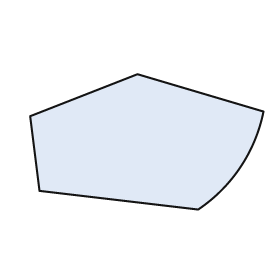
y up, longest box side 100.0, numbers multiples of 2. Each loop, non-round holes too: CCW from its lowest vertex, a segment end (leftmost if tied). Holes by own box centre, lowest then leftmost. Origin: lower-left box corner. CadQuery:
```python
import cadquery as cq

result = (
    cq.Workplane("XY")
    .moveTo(72.0, 0.0)
    .threePointArc((90.0, 18.0), (100.0, 42.0))
    .lineTo(46.0, 58.0)
    .lineTo(0.0, 40.0)
    .lineTo(4.0, 8.0)
    .close()
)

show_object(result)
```